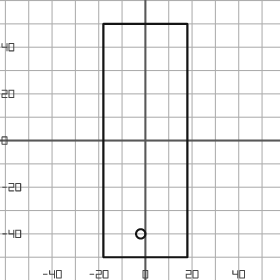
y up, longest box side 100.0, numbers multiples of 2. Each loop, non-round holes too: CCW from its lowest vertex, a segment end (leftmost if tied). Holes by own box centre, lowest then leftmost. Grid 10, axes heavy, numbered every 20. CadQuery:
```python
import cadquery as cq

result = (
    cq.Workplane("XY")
    .moveTo(-18.0, -50.0)
    .lineTo(18.0, -50.0)
    .lineTo(18.0, 50.0)
    .lineTo(-18.0, 50.0)
    .close()
    .moveTo(-2.0, -40.0)
    .circle(2.0)
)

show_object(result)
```